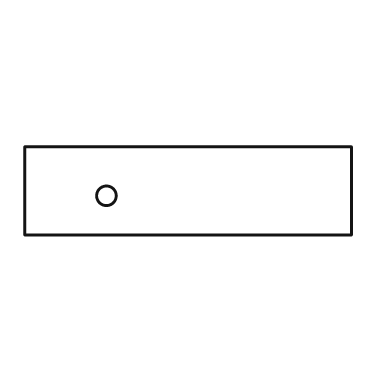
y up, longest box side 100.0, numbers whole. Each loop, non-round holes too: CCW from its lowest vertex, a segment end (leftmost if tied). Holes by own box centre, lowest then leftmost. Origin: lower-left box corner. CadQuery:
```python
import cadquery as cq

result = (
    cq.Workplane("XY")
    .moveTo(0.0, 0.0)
    .lineTo(100.0, 0.0)
    .lineTo(100.0, 27.0)
    .lineTo(0.0, 27.0)
    .close()
    .moveTo(25.0, 12.0)
    .circle(3.0)
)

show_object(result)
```